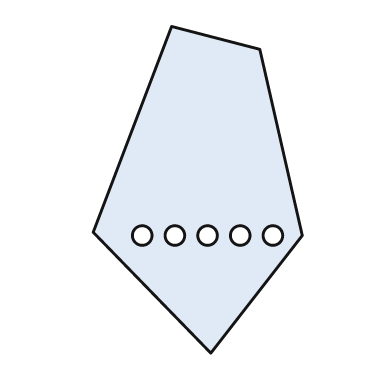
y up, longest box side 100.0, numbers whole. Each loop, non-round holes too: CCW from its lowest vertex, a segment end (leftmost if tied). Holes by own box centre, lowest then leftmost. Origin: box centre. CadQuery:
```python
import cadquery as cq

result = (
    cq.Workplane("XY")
    .moveTo(4.0, -50.0)
    .lineTo(32.0, -14.0)
    .lineTo(19.0, 43.0)
    .lineTo(-8.0, 50.0)
    .lineTo(-32.0, -13.0)
    .close()
    .moveTo(-17.0, -14.0)
    .circle(3.0)
    .moveTo(-7.0, -14.0)
    .circle(3.0)
    .moveTo(3.0, -14.0)
    .circle(3.0)
    .moveTo(13.0, -14.0)
    .circle(3.0)
    .moveTo(23.0, -14.0)
    .circle(3.0)
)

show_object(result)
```